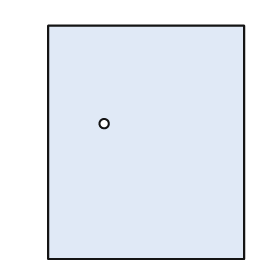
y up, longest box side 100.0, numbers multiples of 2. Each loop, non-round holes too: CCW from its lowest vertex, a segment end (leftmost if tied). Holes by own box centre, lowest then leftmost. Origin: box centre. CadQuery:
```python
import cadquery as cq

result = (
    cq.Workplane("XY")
    .moveTo(-42.0, -50.0)
    .lineTo(42.0, -50.0)
    .lineTo(42.0, 50.0)
    .lineTo(-42.0, 50.0)
    .close()
    .moveTo(-18.0, 8.0)
    .circle(2.0)
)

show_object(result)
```